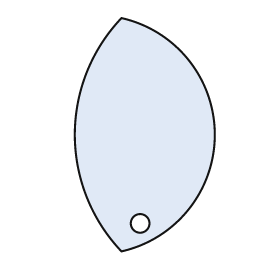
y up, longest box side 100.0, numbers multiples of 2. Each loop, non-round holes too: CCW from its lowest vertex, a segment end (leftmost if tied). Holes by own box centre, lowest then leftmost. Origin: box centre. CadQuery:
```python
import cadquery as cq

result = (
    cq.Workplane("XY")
    .moveTo(-10.0, -50.0)
    .threePointArc((30.0, 0.0), (-10.0, 50.0))
    .threePointArc((-30.0, 0.0), (-10.0, -50.0))
    .close()
    .moveTo(-2.0, -38.0)
    .circle(4.0)
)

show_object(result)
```